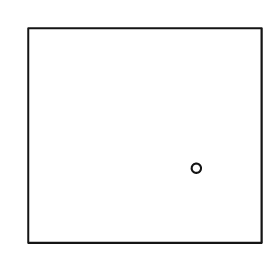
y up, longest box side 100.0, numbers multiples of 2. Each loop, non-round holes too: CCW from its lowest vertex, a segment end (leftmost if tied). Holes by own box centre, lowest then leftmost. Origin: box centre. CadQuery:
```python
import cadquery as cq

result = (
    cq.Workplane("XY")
    .moveTo(-50.0, -46.0)
    .lineTo(50.0, -46.0)
    .lineTo(50.0, 46.0)
    .lineTo(-50.0, 46.0)
    .close()
    .moveTo(22.0, -14.0)
    .circle(2.0)
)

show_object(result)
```